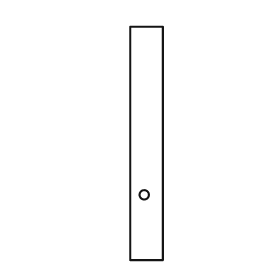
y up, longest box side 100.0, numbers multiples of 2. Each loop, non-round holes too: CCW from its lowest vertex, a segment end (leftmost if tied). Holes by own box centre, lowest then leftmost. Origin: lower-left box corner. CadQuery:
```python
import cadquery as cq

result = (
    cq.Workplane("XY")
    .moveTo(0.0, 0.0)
    .lineTo(14.0, 0.0)
    .lineTo(14.0, 100.0)
    .lineTo(0.0, 100.0)
    .close()
    .moveTo(6.0, 28.0)
    .circle(2.0)
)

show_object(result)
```